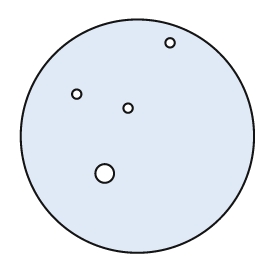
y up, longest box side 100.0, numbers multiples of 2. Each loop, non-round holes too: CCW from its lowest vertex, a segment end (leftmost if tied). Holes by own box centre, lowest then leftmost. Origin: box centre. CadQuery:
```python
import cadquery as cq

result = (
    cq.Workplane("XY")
    .moveTo(0.0, 0.0)
    .circle(50.0)
    .moveTo(-14.0, -16.0)
    .circle(4.0)
    .moveTo(-4.0, 12.0)
    .circle(2.0)
    .moveTo(-26.0, 18.0)
    .circle(2.0)
    .moveTo(14.0, 40.0)
    .circle(2.0)
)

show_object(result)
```